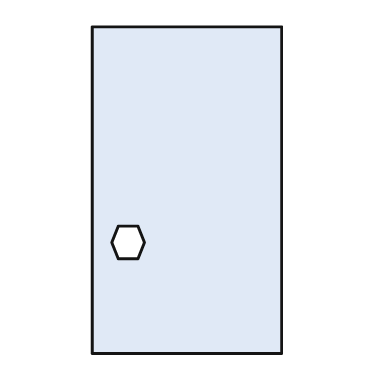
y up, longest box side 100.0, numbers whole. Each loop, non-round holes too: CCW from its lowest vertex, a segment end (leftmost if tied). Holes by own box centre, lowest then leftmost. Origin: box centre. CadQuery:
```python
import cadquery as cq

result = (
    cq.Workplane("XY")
    .moveTo(-29.0, -50.0)
    .lineTo(29.0, -50.0)
    .lineTo(29.0, 50.0)
    .lineTo(-29.0, 50.0)
    .close()
    .moveTo(-21.0, -21.0)
    .lineTo(-15.0, -21.0)
    .lineTo(-13.0, -16.0)
    .lineTo(-15.0, -11.0)
    .lineTo(-21.0, -11.0)
    .lineTo(-23.0, -16.0)
    .close()
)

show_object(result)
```